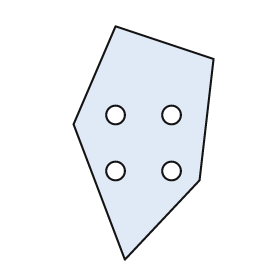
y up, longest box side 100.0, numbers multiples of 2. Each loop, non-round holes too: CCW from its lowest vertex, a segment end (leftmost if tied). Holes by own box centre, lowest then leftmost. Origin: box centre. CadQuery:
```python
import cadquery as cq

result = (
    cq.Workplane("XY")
    .moveTo(-8.0, -50.0)
    .lineTo(24.0, -16.0)
    .lineTo(30.0, 36.0)
    .lineTo(-12.0, 50.0)
    .lineTo(-30.0, 8.0)
    .close()
    .moveTo(-12.0, -12.0)
    .circle(4.0)
    .moveTo(12.0, -12.0)
    .circle(4.0)
    .moveTo(-12.0, 12.0)
    .circle(4.0)
    .moveTo(12.0, 12.0)
    .circle(4.0)
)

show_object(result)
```